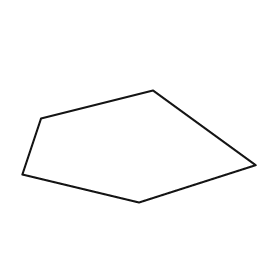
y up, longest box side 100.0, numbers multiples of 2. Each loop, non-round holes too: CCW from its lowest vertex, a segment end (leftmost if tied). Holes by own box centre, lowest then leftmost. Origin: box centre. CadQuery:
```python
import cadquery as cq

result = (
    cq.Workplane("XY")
    .moveTo(0.0, -24.0)
    .lineTo(50.0, -8.0)
    .lineTo(6.0, 24.0)
    .lineTo(-42.0, 12.0)
    .lineTo(-50.0, -12.0)
    .close()
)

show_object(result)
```